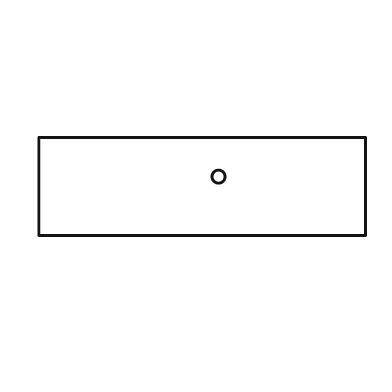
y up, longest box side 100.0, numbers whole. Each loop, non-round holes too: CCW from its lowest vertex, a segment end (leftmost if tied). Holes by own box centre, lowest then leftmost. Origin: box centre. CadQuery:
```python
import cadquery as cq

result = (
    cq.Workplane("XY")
    .moveTo(-50.0, -15.0)
    .lineTo(50.0, -15.0)
    .lineTo(50.0, 15.0)
    .lineTo(-50.0, 15.0)
    .close()
    .moveTo(5.0, 3.0)
    .circle(2.0)
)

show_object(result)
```